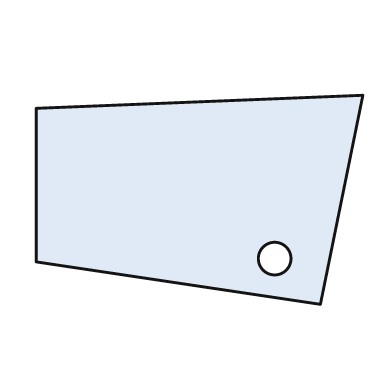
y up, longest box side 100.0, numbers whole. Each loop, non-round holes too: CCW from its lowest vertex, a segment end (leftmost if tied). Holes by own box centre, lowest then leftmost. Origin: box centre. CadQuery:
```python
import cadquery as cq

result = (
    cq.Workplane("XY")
    .moveTo(37.0, -32.0)
    .lineTo(50.0, 32.0)
    .lineTo(-50.0, 28.0)
    .lineTo(-50.0, -19.0)
    .close()
    .moveTo(23.0, -18.0)
    .circle(5.0)
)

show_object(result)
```